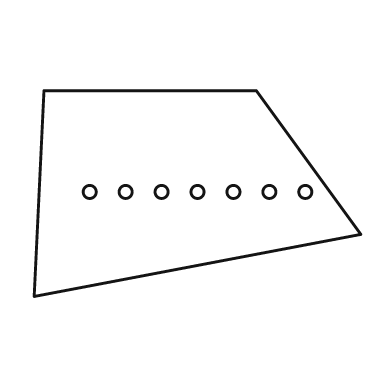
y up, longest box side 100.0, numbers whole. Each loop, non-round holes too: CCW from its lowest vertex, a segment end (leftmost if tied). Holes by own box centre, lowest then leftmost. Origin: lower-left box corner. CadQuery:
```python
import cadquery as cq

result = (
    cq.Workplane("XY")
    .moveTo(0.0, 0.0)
    .lineTo(100.0, 19.0)
    .lineTo(68.0, 63.0)
    .lineTo(3.0, 63.0)
    .close()
    .moveTo(17.0, 32.0)
    .circle(2.0)
    .moveTo(28.0, 32.0)
    .circle(2.0)
    .moveTo(39.0, 32.0)
    .circle(2.0)
    .moveTo(50.0, 32.0)
    .circle(2.0)
    .moveTo(61.0, 32.0)
    .circle(2.0)
    .moveTo(72.0, 32.0)
    .circle(2.0)
    .moveTo(83.0, 32.0)
    .circle(2.0)
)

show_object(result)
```